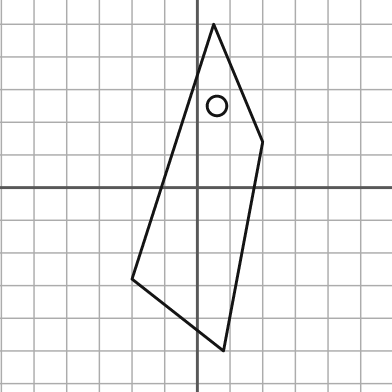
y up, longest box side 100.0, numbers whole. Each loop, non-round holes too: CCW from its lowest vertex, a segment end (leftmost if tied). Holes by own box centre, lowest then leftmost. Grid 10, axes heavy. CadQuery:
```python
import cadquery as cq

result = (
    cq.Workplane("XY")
    .moveTo(8.0, -50.0)
    .lineTo(20.0, 14.0)
    .lineTo(5.0, 50.0)
    .lineTo(-20.0, -28.0)
    .close()
    .moveTo(6.0, 25.0)
    .circle(3.0)
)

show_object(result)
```